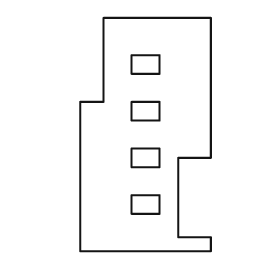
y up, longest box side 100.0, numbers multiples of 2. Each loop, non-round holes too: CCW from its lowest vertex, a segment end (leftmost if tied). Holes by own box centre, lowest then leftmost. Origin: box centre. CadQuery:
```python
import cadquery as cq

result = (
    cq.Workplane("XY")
    .moveTo(-28.0, -50.0)
    .lineTo(28.0, -50.0)
    .lineTo(28.0, -44.0)
    .lineTo(14.0, -44.0)
    .lineTo(14.0, -10.0)
    .lineTo(28.0, -10.0)
    .lineTo(28.0, 50.0)
    .lineTo(-18.0, 50.0)
    .lineTo(-18.0, 14.0)
    .lineTo(-28.0, 14.0)
    .close()
    .moveTo(-6.0, -34.0)
    .lineTo(6.0, -34.0)
    .lineTo(6.0, -26.0)
    .lineTo(-6.0, -26.0)
    .close()
    .moveTo(-6.0, -14.0)
    .lineTo(6.0, -14.0)
    .lineTo(6.0, -6.0)
    .lineTo(-6.0, -6.0)
    .close()
    .moveTo(-6.0, 6.0)
    .lineTo(6.0, 6.0)
    .lineTo(6.0, 14.0)
    .lineTo(-6.0, 14.0)
    .close()
    .moveTo(-6.0, 26.0)
    .lineTo(6.0, 26.0)
    .lineTo(6.0, 34.0)
    .lineTo(-6.0, 34.0)
    .close()
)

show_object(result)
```